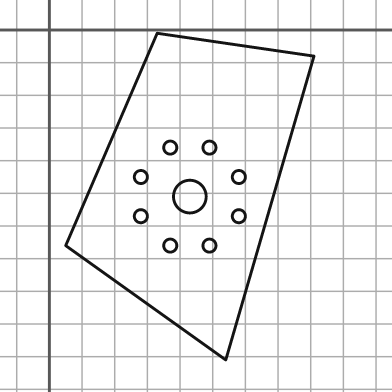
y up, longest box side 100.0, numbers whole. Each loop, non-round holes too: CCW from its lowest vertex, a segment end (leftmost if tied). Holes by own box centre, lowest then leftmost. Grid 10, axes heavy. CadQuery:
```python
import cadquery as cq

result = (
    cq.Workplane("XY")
    .moveTo(54.0, -101.0)
    .lineTo(81.0, -8.0)
    .lineTo(33.0, -1.0)
    .lineTo(5.0, -66.0)
    .close()
    .moveTo(37.0, -66.0)
    .circle(2.0)
    .moveTo(49.0, -66.0)
    .circle(2.0)
    .moveTo(28.0, -57.0)
    .circle(2.0)
    .moveTo(58.0, -57.0)
    .circle(2.0)
    .moveTo(43.0, -51.0)
    .circle(5.0)
    .moveTo(28.0, -45.0)
    .circle(2.0)
    .moveTo(58.0, -45.0)
    .circle(2.0)
    .moveTo(37.0, -36.0)
    .circle(2.0)
    .moveTo(49.0, -36.0)
    .circle(2.0)
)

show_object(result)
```